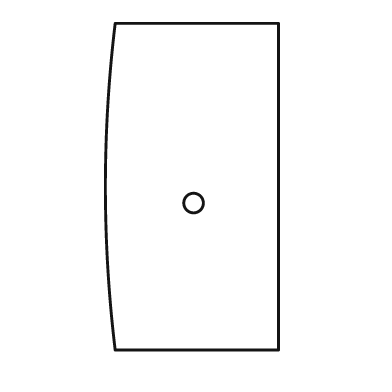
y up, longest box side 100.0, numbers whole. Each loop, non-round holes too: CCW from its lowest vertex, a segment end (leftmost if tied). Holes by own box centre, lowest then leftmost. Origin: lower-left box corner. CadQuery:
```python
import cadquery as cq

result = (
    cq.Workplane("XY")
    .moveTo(3.0, 0.0)
    .lineTo(53.0, 0.0)
    .lineTo(53.0, 100.0)
    .lineTo(3.0, 100.0)
    .threePointArc((0.0, 50.0), (3.0, 0.0))
    .close()
    .moveTo(27.0, 45.0)
    .circle(3.0)
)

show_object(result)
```